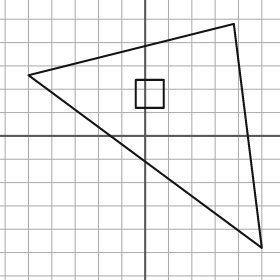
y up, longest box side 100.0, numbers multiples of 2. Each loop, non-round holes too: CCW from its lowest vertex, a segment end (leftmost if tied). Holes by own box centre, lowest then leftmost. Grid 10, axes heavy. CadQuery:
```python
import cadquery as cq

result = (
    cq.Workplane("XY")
    .moveTo(50.0, -48.0)
    .lineTo(38.0, 48.0)
    .lineTo(-50.0, 26.0)
    .close()
    .moveTo(-4.0, 12.0)
    .lineTo(8.0, 12.0)
    .lineTo(8.0, 24.0)
    .lineTo(-4.0, 24.0)
    .close()
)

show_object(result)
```